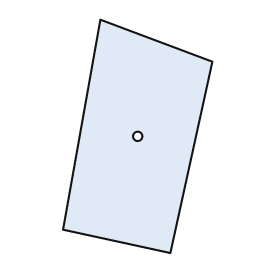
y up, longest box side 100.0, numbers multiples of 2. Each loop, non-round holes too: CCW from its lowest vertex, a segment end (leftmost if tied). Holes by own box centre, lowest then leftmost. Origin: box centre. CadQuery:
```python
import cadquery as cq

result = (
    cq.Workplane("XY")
    .moveTo(14.0, -50.0)
    .lineTo(32.0, 32.0)
    .lineTo(-16.0, 50.0)
    .lineTo(-32.0, -40.0)
    .close()
    .moveTo(0.0, 0.0)
    .circle(2.0)
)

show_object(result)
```